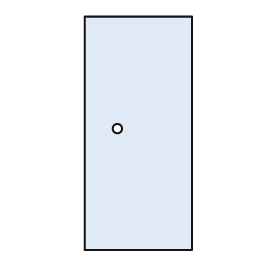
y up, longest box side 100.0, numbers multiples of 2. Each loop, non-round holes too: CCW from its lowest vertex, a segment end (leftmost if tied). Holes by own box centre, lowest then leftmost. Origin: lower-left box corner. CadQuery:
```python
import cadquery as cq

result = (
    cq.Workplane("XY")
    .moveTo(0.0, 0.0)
    .lineTo(46.0, 0.0)
    .lineTo(46.0, 100.0)
    .lineTo(0.0, 100.0)
    .close()
    .moveTo(14.0, 52.0)
    .circle(2.0)
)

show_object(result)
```